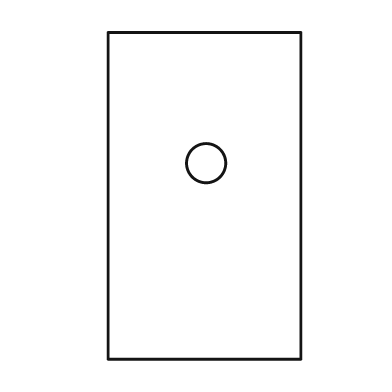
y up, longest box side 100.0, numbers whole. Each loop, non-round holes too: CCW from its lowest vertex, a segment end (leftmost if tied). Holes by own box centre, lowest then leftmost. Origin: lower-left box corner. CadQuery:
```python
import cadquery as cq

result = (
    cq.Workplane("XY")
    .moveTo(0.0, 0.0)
    .lineTo(59.0, 0.0)
    .lineTo(59.0, 100.0)
    .lineTo(0.0, 100.0)
    .close()
    .moveTo(30.0, 60.0)
    .circle(6.0)
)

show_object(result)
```